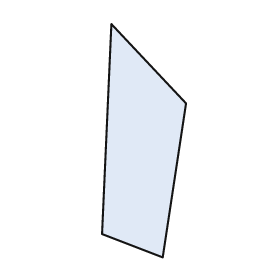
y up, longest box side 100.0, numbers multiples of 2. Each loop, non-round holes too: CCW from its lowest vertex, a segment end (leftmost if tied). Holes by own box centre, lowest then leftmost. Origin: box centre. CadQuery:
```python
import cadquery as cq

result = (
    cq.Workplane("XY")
    .moveTo(8.0, -50.0)
    .lineTo(18.0, 16.0)
    .lineTo(-14.0, 50.0)
    .lineTo(-18.0, -40.0)
    .close()
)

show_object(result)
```